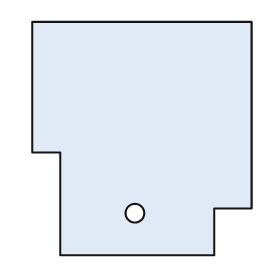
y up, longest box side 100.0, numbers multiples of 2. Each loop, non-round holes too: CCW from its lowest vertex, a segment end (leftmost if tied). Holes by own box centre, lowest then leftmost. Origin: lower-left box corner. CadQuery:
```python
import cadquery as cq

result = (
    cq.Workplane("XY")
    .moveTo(12.0, 0.0)
    .lineTo(78.0, 0.0)
    .lineTo(78.0, 20.0)
    .lineTo(94.0, 20.0)
    .lineTo(94.0, 100.0)
    .lineTo(0.0, 100.0)
    .lineTo(0.0, 44.0)
    .lineTo(12.0, 44.0)
    .close()
    .moveTo(44.0, 18.0)
    .circle(4.0)
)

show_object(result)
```